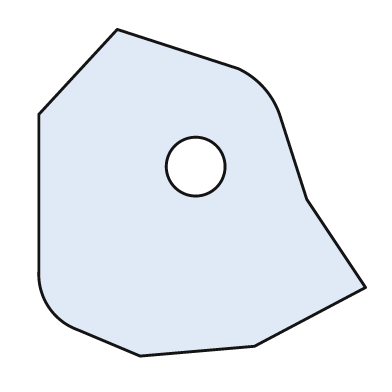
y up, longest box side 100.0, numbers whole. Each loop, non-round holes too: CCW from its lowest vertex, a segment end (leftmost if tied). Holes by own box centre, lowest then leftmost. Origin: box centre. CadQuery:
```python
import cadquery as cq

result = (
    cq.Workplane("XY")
    .moveTo(-19.0, -50.0)
    .lineTo(16.0, -47.0)
    .lineTo(50.0, -29.0)
    .lineTo(32.0, -2.0)
    .lineTo(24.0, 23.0)
    .threePointArc((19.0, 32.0), (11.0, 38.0))
    .lineTo(-26.0, 50.0)
    .lineTo(-50.0, 24.0)
    .lineTo(-50.0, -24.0)
    .threePointArc((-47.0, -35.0), (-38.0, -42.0))
    .close()
    .moveTo(-2.0, 8.0)
    .circle(9.0)
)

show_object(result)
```